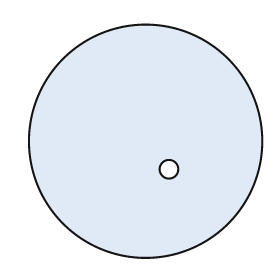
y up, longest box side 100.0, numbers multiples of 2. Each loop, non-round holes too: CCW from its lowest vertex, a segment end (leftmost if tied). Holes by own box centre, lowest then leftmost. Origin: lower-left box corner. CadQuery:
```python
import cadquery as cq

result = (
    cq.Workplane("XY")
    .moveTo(50.0, 50.0)
    .circle(50.0)
    .moveTo(60.0, 38.0)
    .circle(4.0)
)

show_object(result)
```